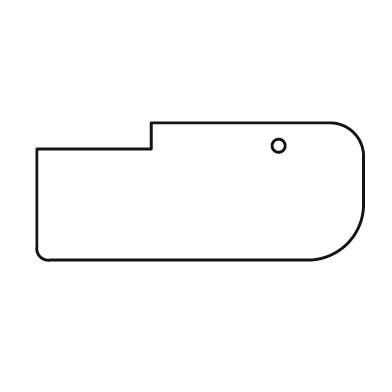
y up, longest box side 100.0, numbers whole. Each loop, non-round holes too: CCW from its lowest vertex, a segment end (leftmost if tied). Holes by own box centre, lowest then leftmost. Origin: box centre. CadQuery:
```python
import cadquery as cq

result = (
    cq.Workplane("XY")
    .moveTo(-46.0, -21.0)
    .lineTo(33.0, -21.0)
    .threePointArc((45.0, -16.0), (50.0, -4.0))
    .lineTo(50.0, 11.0)
    .threePointArc((47.0, 18.0), (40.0, 21.0))
    .lineTo(-15.0, 21.0)
    .lineTo(-15.0, 13.0)
    .lineTo(-50.0, 13.0)
    .lineTo(-50.0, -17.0)
    .threePointArc((-49.0, -20.0), (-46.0, -21.0))
    .close()
    .moveTo(24.0, 14.0)
    .circle(2.0)
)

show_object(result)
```